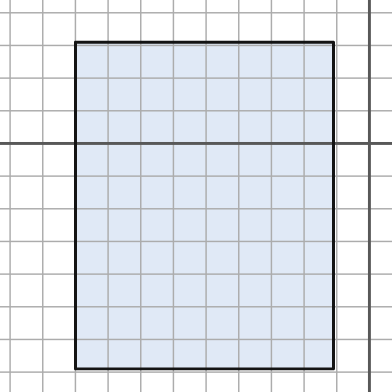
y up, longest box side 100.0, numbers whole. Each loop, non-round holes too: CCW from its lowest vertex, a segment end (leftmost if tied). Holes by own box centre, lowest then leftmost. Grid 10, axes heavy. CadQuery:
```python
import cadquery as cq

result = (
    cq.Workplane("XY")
    .moveTo(-90.0, -69.0)
    .lineTo(-11.0, -69.0)
    .lineTo(-11.0, 31.0)
    .lineTo(-90.0, 31.0)
    .close()
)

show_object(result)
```